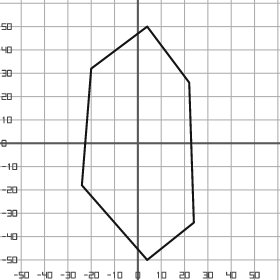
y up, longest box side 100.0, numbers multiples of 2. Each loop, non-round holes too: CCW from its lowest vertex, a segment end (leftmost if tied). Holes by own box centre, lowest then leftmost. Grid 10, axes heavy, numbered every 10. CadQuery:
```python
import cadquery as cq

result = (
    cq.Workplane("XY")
    .moveTo(4.0, -50.0)
    .lineTo(24.0, -34.0)
    .lineTo(22.0, 26.0)
    .lineTo(4.0, 50.0)
    .lineTo(-20.0, 32.0)
    .lineTo(-24.0, -18.0)
    .close()
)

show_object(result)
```